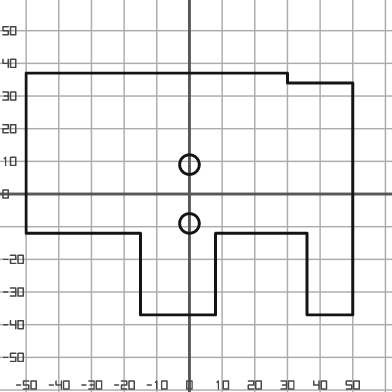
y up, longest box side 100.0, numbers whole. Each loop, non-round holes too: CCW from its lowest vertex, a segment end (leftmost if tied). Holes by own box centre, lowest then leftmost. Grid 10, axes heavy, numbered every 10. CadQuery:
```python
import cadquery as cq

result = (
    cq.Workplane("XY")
    .moveTo(-15.0, -37.0)
    .lineTo(8.0, -37.0)
    .lineTo(8.0, -12.0)
    .lineTo(36.0, -12.0)
    .lineTo(36.0, -37.0)
    .lineTo(50.0, -37.0)
    .lineTo(50.0, 34.0)
    .lineTo(30.0, 34.0)
    .lineTo(30.0, 37.0)
    .lineTo(-50.0, 37.0)
    .lineTo(-50.0, -12.0)
    .lineTo(-15.0, -12.0)
    .close()
    .moveTo(0.0, -9.0)
    .circle(3.0)
    .moveTo(0.0, 9.0)
    .circle(3.0)
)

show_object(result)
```